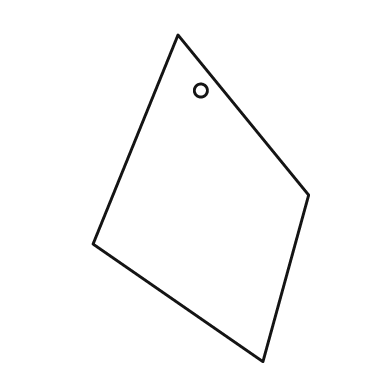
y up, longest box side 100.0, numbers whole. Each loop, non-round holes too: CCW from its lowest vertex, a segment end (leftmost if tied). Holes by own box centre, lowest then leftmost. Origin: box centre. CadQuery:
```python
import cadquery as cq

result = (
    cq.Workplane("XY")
    .moveTo(19.0, -50.0)
    .lineTo(33.0, 1.0)
    .lineTo(-7.0, 50.0)
    .lineTo(-33.0, -14.0)
    .close()
    .moveTo(0.0, 33.0)
    .circle(2.0)
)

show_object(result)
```